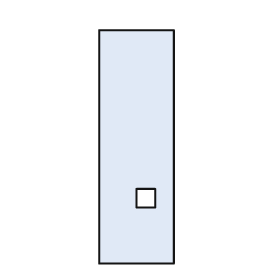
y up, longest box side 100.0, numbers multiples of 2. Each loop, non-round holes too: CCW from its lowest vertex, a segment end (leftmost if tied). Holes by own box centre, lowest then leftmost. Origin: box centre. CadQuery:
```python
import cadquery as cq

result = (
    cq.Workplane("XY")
    .moveTo(-16.0, -50.0)
    .lineTo(16.0, -50.0)
    .lineTo(16.0, 50.0)
    .lineTo(-16.0, 50.0)
    .close()
    .moveTo(0.0, -26.0)
    .lineTo(8.0, -26.0)
    .lineTo(8.0, -18.0)
    .lineTo(0.0, -18.0)
    .close()
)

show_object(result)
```